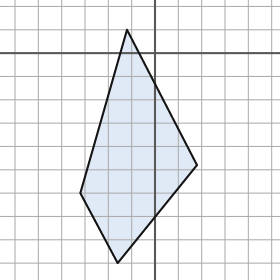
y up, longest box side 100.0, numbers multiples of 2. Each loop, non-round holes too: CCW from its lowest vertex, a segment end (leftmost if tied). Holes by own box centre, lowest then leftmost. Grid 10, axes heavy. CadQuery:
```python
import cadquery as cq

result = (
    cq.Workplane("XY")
    .moveTo(-16.0, -90.0)
    .lineTo(18.0, -48.0)
    .lineTo(-12.0, 10.0)
    .lineTo(-32.0, -60.0)
    .close()
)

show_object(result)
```